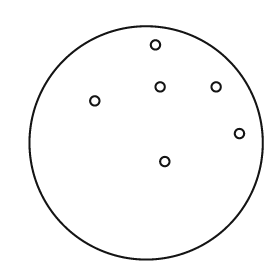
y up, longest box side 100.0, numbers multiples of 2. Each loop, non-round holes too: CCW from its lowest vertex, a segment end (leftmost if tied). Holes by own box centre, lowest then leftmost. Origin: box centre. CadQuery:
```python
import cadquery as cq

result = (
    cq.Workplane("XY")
    .moveTo(0.0, 0.0)
    .circle(50.0)
    .moveTo(8.0, -8.0)
    .circle(2.0)
    .moveTo(40.0, 4.0)
    .circle(2.0)
    .moveTo(-22.0, 18.0)
    .circle(2.0)
    .moveTo(6.0, 24.0)
    .circle(2.0)
    .moveTo(30.0, 24.0)
    .circle(2.0)
    .moveTo(4.0, 42.0)
    .circle(2.0)
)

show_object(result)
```